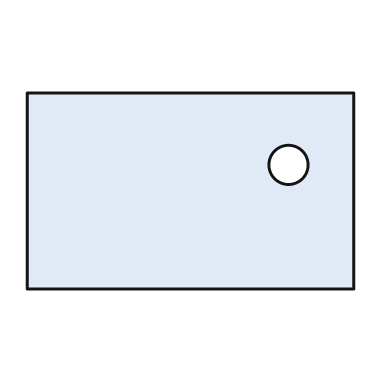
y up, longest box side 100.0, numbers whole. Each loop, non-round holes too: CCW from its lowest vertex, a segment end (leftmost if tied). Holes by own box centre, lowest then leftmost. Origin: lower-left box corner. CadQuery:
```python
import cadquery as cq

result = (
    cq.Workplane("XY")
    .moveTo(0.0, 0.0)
    .lineTo(100.0, 0.0)
    .lineTo(100.0, 60.0)
    .lineTo(0.0, 60.0)
    .close()
    .moveTo(80.0, 38.0)
    .circle(6.0)
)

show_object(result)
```